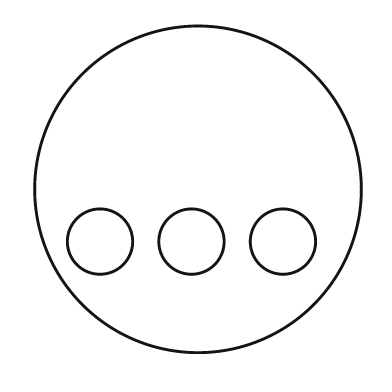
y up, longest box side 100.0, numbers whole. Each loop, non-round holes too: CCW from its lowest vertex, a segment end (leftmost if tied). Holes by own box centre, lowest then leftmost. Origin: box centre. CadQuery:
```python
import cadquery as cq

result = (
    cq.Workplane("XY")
    .moveTo(0.0, 0.0)
    .circle(50.0)
    .moveTo(-30.0, -16.0)
    .circle(10.0)
    .moveTo(-2.0, -16.0)
    .circle(10.0)
    .moveTo(26.0, -16.0)
    .circle(10.0)
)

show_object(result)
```